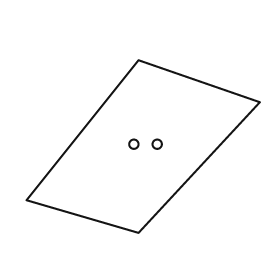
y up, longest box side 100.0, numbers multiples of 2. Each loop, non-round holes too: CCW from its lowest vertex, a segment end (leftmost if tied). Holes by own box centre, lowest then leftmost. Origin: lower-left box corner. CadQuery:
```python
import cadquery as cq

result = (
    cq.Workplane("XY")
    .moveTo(48.0, 0.0)
    .lineTo(100.0, 56.0)
    .lineTo(48.0, 74.0)
    .lineTo(0.0, 14.0)
    .close()
    .moveTo(46.0, 38.0)
    .circle(2.0)
    .moveTo(56.0, 38.0)
    .circle(2.0)
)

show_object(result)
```